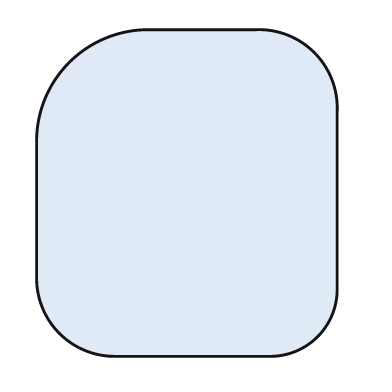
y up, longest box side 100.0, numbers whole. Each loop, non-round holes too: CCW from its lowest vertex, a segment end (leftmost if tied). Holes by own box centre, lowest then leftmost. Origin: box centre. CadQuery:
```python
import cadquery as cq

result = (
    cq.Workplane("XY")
    .moveTo(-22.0, -50.0)
    .lineTo(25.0, -50.0)
    .threePointArc((40.0, -44.0), (46.0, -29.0))
    .lineTo(46.0, 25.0)
    .threePointArc((39.0, 43.0), (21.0, 50.0))
    .lineTo(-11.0, 50.0)
    .threePointArc((-36.0, 40.0), (-46.0, 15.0))
    .lineTo(-46.0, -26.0)
    .threePointArc((-39.0, -43.0), (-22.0, -50.0))
    .close()
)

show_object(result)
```